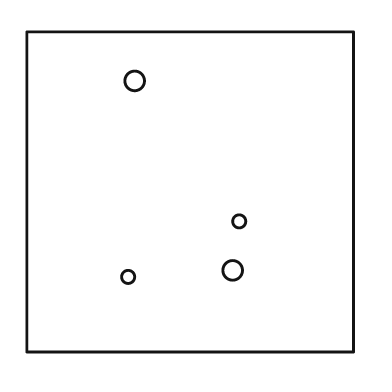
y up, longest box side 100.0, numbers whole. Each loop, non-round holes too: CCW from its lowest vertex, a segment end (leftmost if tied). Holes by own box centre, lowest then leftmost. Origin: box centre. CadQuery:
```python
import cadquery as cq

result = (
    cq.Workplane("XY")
    .moveTo(-50.0, -49.0)
    .lineTo(50.0, -49.0)
    .lineTo(50.0, 49.0)
    .lineTo(-50.0, 49.0)
    .close()
    .moveTo(-19.0, -26.0)
    .circle(2.0)
    .moveTo(13.0, -24.0)
    .circle(3.0)
    .moveTo(15.0, -9.0)
    .circle(2.0)
    .moveTo(-17.0, 34.0)
    .circle(3.0)
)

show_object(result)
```